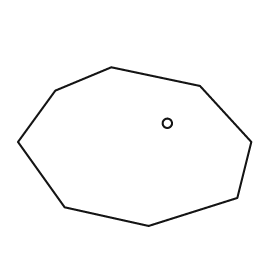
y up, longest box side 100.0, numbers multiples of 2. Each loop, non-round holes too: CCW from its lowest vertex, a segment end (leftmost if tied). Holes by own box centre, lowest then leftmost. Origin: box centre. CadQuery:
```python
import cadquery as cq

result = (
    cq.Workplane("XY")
    .moveTo(6.0, -34.0)
    .lineTo(44.0, -22.0)
    .lineTo(50.0, 2.0)
    .lineTo(28.0, 26.0)
    .lineTo(-10.0, 34.0)
    .lineTo(-34.0, 24.0)
    .lineTo(-50.0, 2.0)
    .lineTo(-30.0, -26.0)
    .close()
    .moveTo(14.0, 10.0)
    .circle(2.0)
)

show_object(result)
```